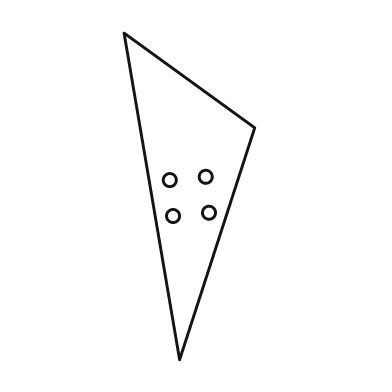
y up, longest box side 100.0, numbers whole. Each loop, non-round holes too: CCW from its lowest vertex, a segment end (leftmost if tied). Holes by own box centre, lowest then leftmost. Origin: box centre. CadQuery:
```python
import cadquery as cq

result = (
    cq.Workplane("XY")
    .moveTo(-3.0, -50.0)
    .lineTo(20.0, 21.0)
    .lineTo(-20.0, 50.0)
    .close()
    .moveTo(-5.0, -6.0)
    .circle(2.0)
    .moveTo(6.0, -5.0)
    .circle(2.0)
    .moveTo(-6.0, 5.0)
    .circle(2.0)
    .moveTo(5.0, 6.0)
    .circle(2.0)
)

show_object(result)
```